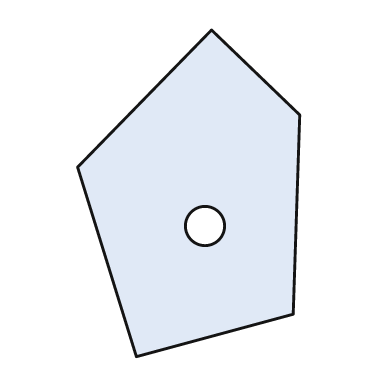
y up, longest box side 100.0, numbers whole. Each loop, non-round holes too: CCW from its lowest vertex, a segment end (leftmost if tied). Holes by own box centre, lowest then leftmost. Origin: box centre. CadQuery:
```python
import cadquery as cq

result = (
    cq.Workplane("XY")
    .moveTo(-16.0, -50.0)
    .lineTo(32.0, -37.0)
    .lineTo(34.0, 24.0)
    .lineTo(7.0, 50.0)
    .lineTo(-34.0, 8.0)
    .close()
    .moveTo(5.0, -10.0)
    .circle(6.0)
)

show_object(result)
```